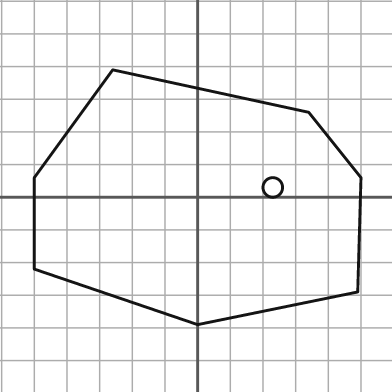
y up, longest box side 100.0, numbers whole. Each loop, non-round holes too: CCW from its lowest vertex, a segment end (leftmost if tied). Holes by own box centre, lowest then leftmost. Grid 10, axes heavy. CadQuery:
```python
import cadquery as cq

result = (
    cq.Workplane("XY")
    .moveTo(0.0, -39.0)
    .lineTo(49.0, -29.0)
    .lineTo(50.0, 6.0)
    .lineTo(34.0, 26.0)
    .lineTo(-26.0, 39.0)
    .lineTo(-50.0, 6.0)
    .lineTo(-50.0, -22.0)
    .close()
    .moveTo(23.0, 3.0)
    .circle(3.0)
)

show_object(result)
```